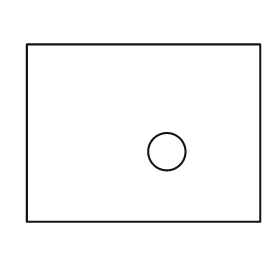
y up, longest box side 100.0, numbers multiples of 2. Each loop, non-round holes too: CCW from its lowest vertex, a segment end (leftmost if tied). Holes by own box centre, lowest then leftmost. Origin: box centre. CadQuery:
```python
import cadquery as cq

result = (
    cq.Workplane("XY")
    .moveTo(-50.0, -38.0)
    .lineTo(50.0, -38.0)
    .lineTo(50.0, 38.0)
    .lineTo(-50.0, 38.0)
    .close()
    .moveTo(10.0, -8.0)
    .circle(8.0)
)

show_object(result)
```